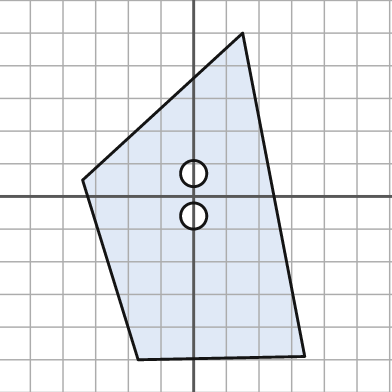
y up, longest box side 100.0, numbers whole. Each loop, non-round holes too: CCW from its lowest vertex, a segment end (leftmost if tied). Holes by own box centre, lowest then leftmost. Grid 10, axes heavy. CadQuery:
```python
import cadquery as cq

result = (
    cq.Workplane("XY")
    .moveTo(-17.0, -50.0)
    .lineTo(34.0, -49.0)
    .lineTo(15.0, 50.0)
    .lineTo(-34.0, 5.0)
    .close()
    .moveTo(0.0, -6.0)
    .circle(4.0)
    .moveTo(0.0, 7.0)
    .circle(4.0)
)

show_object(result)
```